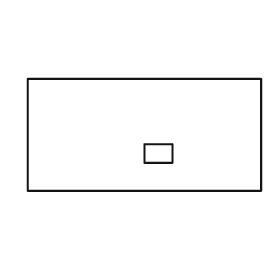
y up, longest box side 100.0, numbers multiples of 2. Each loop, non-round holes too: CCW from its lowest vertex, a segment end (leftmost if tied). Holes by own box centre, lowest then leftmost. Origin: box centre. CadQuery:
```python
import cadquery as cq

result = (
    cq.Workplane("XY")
    .moveTo(-50.0, -24.0)
    .lineTo(50.0, -24.0)
    .lineTo(50.0, 24.0)
    .lineTo(-50.0, 24.0)
    .close()
    .moveTo(0.0, -12.0)
    .lineTo(12.0, -12.0)
    .lineTo(12.0, -4.0)
    .lineTo(0.0, -4.0)
    .close()
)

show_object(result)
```